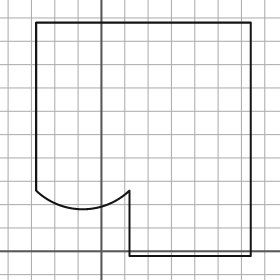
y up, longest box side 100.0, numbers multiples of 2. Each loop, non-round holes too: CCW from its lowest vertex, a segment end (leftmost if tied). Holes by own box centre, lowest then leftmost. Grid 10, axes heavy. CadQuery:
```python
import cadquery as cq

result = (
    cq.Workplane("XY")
    .moveTo(12.0, -2.0)
    .lineTo(64.0, -2.0)
    .lineTo(64.0, 98.0)
    .lineTo(-28.0, 98.0)
    .lineTo(-28.0, 26.0)
    .threePointArc((-8.0, 18.0), (12.0, 26.0))
    .close()
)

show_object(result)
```